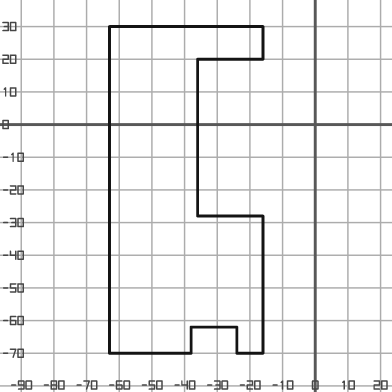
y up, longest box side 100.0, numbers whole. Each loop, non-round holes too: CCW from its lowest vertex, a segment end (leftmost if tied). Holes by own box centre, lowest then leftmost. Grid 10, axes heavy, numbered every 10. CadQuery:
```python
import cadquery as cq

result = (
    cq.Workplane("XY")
    .moveTo(-63.0, -70.0)
    .lineTo(-38.0, -70.0)
    .lineTo(-38.0, -62.0)
    .lineTo(-24.0, -62.0)
    .lineTo(-24.0, -70.0)
    .lineTo(-16.0, -70.0)
    .lineTo(-16.0, -28.0)
    .lineTo(-36.0, -28.0)
    .lineTo(-36.0, 20.0)
    .lineTo(-16.0, 20.0)
    .lineTo(-16.0, 30.0)
    .lineTo(-63.0, 30.0)
    .close()
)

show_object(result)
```